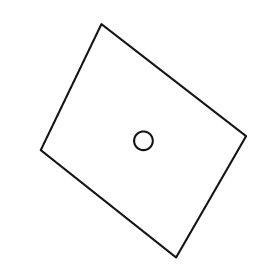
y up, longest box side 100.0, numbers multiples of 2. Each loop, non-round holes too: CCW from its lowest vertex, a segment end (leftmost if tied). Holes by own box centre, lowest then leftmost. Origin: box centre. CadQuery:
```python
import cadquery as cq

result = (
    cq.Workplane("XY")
    .moveTo(14.0, -50.0)
    .lineTo(44.0, 2.0)
    .lineTo(-18.0, 50.0)
    .lineTo(-44.0, -4.0)
    .close()
    .moveTo(0.0, 0.0)
    .circle(4.0)
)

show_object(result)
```